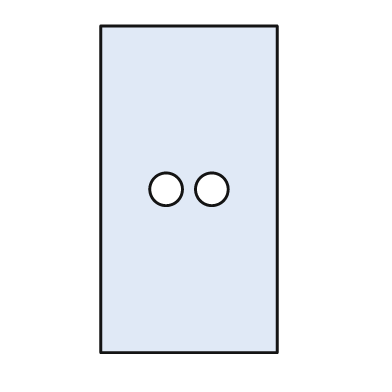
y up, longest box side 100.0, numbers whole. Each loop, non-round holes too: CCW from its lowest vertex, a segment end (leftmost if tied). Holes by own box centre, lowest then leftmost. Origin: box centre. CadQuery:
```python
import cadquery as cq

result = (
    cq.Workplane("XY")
    .moveTo(-27.0, -50.0)
    .lineTo(27.0, -50.0)
    .lineTo(27.0, 50.0)
    .lineTo(-27.0, 50.0)
    .close()
    .moveTo(-7.0, 0.0)
    .circle(5.0)
    .moveTo(7.0, 0.0)
    .circle(5.0)
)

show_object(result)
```